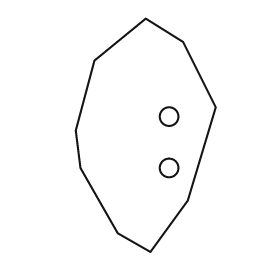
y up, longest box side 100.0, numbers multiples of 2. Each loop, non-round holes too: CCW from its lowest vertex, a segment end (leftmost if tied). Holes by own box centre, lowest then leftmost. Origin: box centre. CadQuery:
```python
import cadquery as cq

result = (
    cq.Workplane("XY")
    .moveTo(2.0, -50.0)
    .lineTo(18.0, -28.0)
    .lineTo(30.0, 12.0)
    .lineTo(16.0, 40.0)
    .lineTo(0.0, 50.0)
    .lineTo(-22.0, 32.0)
    .lineTo(-30.0, 2.0)
    .lineTo(-28.0, -14.0)
    .lineTo(-12.0, -42.0)
    .close()
    .moveTo(10.0, -14.0)
    .circle(4.0)
    .moveTo(10.0, 8.0)
    .circle(4.0)
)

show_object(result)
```